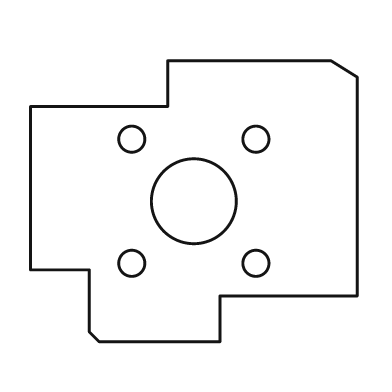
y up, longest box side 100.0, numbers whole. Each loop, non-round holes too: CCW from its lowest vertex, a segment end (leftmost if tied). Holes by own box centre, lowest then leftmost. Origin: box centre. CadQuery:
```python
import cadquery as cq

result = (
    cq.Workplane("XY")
    .moveTo(-29.0, -43.0)
    .lineTo(8.0, -43.0)
    .lineTo(8.0, -29.0)
    .lineTo(50.0, -29.0)
    .lineTo(50.0, 38.0)
    .lineTo(42.0, 43.0)
    .lineTo(-8.0, 43.0)
    .lineTo(-8.0, 29.0)
    .lineTo(-50.0, 29.0)
    .lineTo(-50.0, -21.0)
    .lineTo(-32.0, -21.0)
    .lineTo(-32.0, -40.0)
    .close()
    .moveTo(-19.0, -19.0)
    .circle(4.0)
    .moveTo(19.0, -19.0)
    .circle(4.0)
    .moveTo(0.0, 0.0)
    .circle(13.0)
    .moveTo(-19.0, 19.0)
    .circle(4.0)
    .moveTo(19.0, 19.0)
    .circle(4.0)
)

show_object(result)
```